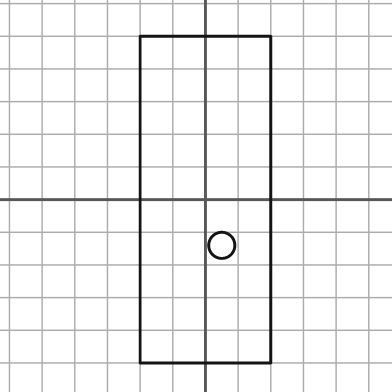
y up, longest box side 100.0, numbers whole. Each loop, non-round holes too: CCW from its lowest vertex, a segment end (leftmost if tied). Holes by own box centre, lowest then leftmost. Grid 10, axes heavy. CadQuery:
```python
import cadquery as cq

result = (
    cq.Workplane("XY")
    .moveTo(-20.0, -50.0)
    .lineTo(20.0, -50.0)
    .lineTo(20.0, 50.0)
    .lineTo(-20.0, 50.0)
    .close()
    .moveTo(5.0, -14.0)
    .circle(4.0)
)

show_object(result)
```